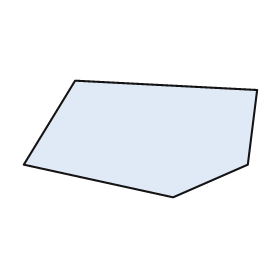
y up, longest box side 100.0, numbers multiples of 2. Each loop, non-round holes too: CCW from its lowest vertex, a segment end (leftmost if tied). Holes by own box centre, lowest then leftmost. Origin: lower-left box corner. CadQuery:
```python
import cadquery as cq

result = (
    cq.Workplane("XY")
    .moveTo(64.0, 0.0)
    .lineTo(96.0, 14.0)
    .lineTo(100.0, 46.0)
    .lineTo(22.0, 50.0)
    .lineTo(0.0, 14.0)
    .close()
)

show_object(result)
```